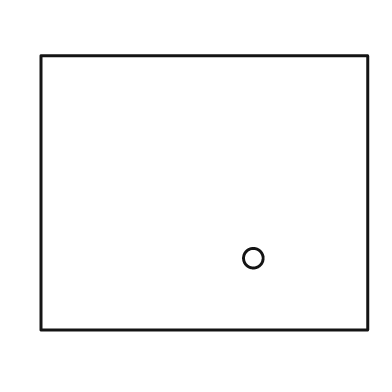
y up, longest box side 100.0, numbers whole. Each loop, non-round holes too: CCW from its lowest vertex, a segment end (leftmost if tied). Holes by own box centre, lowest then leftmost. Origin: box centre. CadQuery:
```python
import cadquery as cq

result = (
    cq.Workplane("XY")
    .moveTo(-50.0, -42.0)
    .lineTo(50.0, -42.0)
    .lineTo(50.0, 42.0)
    .lineTo(-50.0, 42.0)
    .close()
    .moveTo(15.0, -20.0)
    .circle(3.0)
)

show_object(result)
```